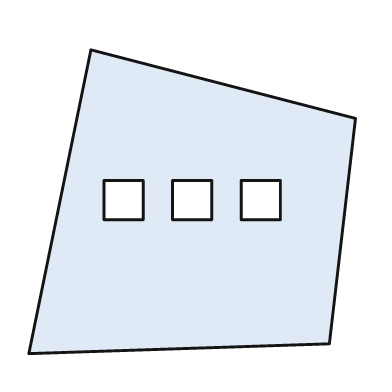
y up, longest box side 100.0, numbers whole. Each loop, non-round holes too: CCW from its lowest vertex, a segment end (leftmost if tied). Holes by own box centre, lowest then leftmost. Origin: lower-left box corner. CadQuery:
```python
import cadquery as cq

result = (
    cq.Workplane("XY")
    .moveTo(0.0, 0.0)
    .lineTo(92.0, 3.0)
    .lineTo(100.0, 72.0)
    .lineTo(19.0, 93.0)
    .close()
    .moveTo(23.0, 41.0)
    .lineTo(35.0, 41.0)
    .lineTo(35.0, 53.0)
    .lineTo(23.0, 53.0)
    .close()
    .moveTo(44.0, 41.0)
    .lineTo(56.0, 41.0)
    .lineTo(56.0, 53.0)
    .lineTo(44.0, 53.0)
    .close()
    .moveTo(65.0, 41.0)
    .lineTo(77.0, 41.0)
    .lineTo(77.0, 53.0)
    .lineTo(65.0, 53.0)
    .close()
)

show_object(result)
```